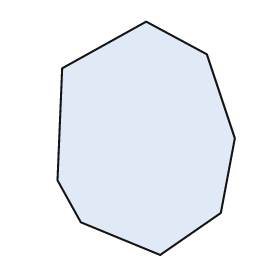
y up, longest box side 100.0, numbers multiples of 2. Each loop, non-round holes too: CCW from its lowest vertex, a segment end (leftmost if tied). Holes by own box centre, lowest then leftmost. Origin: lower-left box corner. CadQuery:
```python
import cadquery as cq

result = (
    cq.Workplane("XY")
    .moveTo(44.0, 0.0)
    .lineTo(70.0, 18.0)
    .lineTo(76.0, 50.0)
    .lineTo(64.0, 86.0)
    .lineTo(38.0, 100.0)
    .lineTo(2.0, 80.0)
    .lineTo(0.0, 32.0)
    .lineTo(10.0, 14.0)
    .close()
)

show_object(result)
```